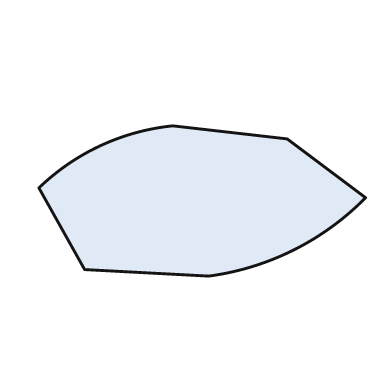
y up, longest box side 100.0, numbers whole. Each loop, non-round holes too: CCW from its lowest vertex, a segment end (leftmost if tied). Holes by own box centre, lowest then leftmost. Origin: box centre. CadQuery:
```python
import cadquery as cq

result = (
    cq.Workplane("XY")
    .moveTo(2.0, -23.0)
    .threePointArc((28.0, -15.0), (50.0, 1.0))
    .lineTo(26.0, 19.0)
    .lineTo(-9.0, 23.0)
    .threePointArc((-31.0, 17.0), (-50.0, 4.0))
    .lineTo(-36.0, -21.0)
    .close()
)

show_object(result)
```